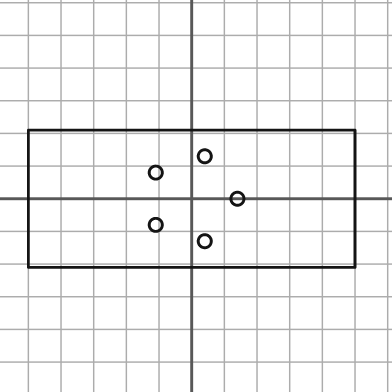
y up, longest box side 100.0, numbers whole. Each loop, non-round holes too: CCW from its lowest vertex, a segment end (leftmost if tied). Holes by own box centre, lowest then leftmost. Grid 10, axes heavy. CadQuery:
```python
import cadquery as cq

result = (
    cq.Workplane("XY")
    .moveTo(-50.0, -21.0)
    .lineTo(50.0, -21.0)
    .lineTo(50.0, 21.0)
    .lineTo(-50.0, 21.0)
    .close()
    .moveTo(4.0, -13.0)
    .circle(2.0)
    .moveTo(-11.0, -8.0)
    .circle(2.0)
    .moveTo(14.0, 0.0)
    .circle(2.0)
    .moveTo(-11.0, 8.0)
    .circle(2.0)
    .moveTo(4.0, 13.0)
    .circle(2.0)
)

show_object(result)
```